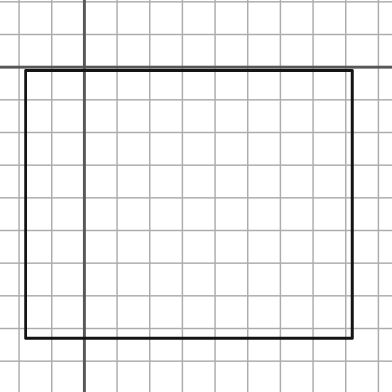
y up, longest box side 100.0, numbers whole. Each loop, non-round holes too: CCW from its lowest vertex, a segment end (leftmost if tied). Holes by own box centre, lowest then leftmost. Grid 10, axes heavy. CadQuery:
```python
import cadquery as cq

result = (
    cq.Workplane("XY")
    .moveTo(-18.0, -83.0)
    .lineTo(82.0, -83.0)
    .lineTo(82.0, -1.0)
    .lineTo(-18.0, -1.0)
    .close()
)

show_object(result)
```